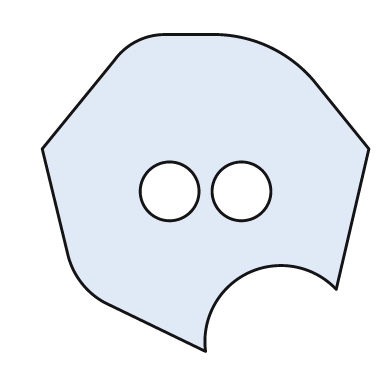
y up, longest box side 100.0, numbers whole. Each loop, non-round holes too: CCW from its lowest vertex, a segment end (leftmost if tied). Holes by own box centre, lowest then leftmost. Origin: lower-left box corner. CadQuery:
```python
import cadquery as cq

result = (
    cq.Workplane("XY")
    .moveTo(50.0, 0.0)
    .threePointArc((63.0, 24.0), (90.0, 19.0))
    .lineTo(100.0, 62.0)
    .lineTo(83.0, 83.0)
    .threePointArc((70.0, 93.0), (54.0, 97.0))
    .lineTo(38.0, 97.0)
    .threePointArc((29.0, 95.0), (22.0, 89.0))
    .lineTo(0.0, 62.0)
    .lineTo(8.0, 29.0)
    .threePointArc((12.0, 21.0), (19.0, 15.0))
    .close()
    .moveTo(39.0, 49.0)
    .circle(9.0)
    .moveTo(61.0, 49.0)
    .circle(9.0)
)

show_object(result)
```